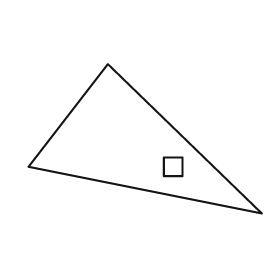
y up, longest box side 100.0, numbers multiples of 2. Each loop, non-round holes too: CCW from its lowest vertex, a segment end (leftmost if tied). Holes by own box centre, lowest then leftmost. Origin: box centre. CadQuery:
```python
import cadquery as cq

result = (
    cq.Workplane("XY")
    .moveTo(50.0, -32.0)
    .lineTo(-16.0, 32.0)
    .lineTo(-50.0, -12.0)
    .close()
    .moveTo(8.0, -16.0)
    .lineTo(16.0, -16.0)
    .lineTo(16.0, -8.0)
    .lineTo(8.0, -8.0)
    .close()
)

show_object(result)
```